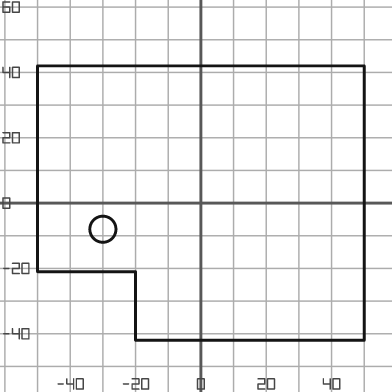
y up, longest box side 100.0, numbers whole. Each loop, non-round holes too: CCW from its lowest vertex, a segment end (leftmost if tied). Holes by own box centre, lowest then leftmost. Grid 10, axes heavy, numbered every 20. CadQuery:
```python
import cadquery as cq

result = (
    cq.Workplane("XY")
    .moveTo(-20.0, -42.0)
    .lineTo(50.0, -42.0)
    .lineTo(50.0, 42.0)
    .lineTo(-50.0, 42.0)
    .lineTo(-50.0, -21.0)
    .lineTo(-20.0, -21.0)
    .close()
    .moveTo(-30.0, -8.0)
    .circle(4.0)
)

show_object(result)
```